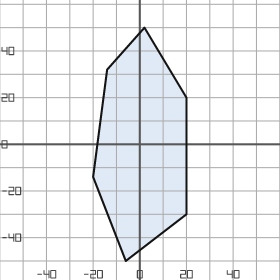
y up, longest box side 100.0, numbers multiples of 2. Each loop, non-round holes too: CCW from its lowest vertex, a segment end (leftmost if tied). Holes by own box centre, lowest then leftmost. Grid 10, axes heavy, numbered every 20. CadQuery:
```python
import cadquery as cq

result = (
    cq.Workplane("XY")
    .moveTo(-6.0, -50.0)
    .lineTo(20.0, -30.0)
    .lineTo(20.0, 20.0)
    .lineTo(2.0, 50.0)
    .lineTo(-14.0, 32.0)
    .lineTo(-20.0, -14.0)
    .close()
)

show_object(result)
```